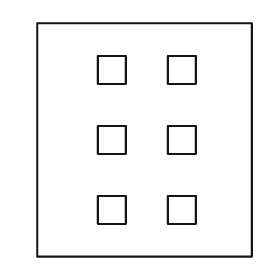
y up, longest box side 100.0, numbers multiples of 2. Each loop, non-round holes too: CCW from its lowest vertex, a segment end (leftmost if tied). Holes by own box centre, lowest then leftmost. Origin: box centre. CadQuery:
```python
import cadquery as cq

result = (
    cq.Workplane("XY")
    .moveTo(-46.0, -50.0)
    .lineTo(46.0, -50.0)
    .lineTo(46.0, 50.0)
    .lineTo(-46.0, 50.0)
    .close()
    .moveTo(-20.0, -36.0)
    .lineTo(-8.0, -36.0)
    .lineTo(-8.0, -24.0)
    .lineTo(-20.0, -24.0)
    .close()
    .moveTo(10.0, -36.0)
    .lineTo(22.0, -36.0)
    .lineTo(22.0, -24.0)
    .lineTo(10.0, -24.0)
    .close()
    .moveTo(-20.0, -6.0)
    .lineTo(-8.0, -6.0)
    .lineTo(-8.0, 6.0)
    .lineTo(-20.0, 6.0)
    .close()
    .moveTo(10.0, -6.0)
    .lineTo(22.0, -6.0)
    .lineTo(22.0, 6.0)
    .lineTo(10.0, 6.0)
    .close()
    .moveTo(-20.0, 24.0)
    .lineTo(-8.0, 24.0)
    .lineTo(-8.0, 36.0)
    .lineTo(-20.0, 36.0)
    .close()
    .moveTo(10.0, 24.0)
    .lineTo(22.0, 24.0)
    .lineTo(22.0, 36.0)
    .lineTo(10.0, 36.0)
    .close()
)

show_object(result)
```